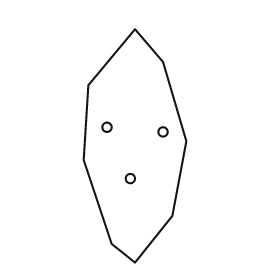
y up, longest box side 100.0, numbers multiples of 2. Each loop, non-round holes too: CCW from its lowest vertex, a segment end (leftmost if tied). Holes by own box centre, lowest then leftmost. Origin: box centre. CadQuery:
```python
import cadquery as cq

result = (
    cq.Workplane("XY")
    .moveTo(0.0, -50.0)
    .lineTo(16.0, -30.0)
    .lineTo(22.0, 2.0)
    .lineTo(12.0, 36.0)
    .lineTo(0.0, 50.0)
    .lineTo(-20.0, 26.0)
    .lineTo(-22.0, -6.0)
    .lineTo(-10.0, -42.0)
    .close()
    .moveTo(-2.0, -14.0)
    .circle(2.0)
    .moveTo(12.0, 6.0)
    .circle(2.0)
    .moveTo(-12.0, 8.0)
    .circle(2.0)
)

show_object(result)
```